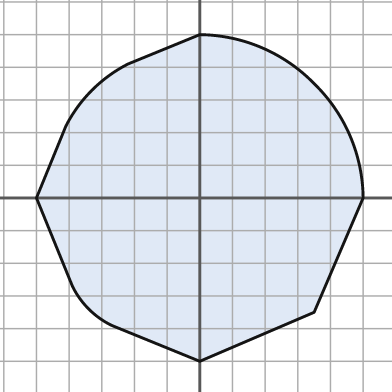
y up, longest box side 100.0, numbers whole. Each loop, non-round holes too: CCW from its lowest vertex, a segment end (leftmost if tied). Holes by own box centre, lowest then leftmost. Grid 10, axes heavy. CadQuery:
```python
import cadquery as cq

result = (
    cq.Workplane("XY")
    .moveTo(0.0, -50.0)
    .lineTo(35.0, -35.0)
    .lineTo(50.0, 0.0)
    .threePointArc((46.0, 19.0), (35.0, 35.0))
    .threePointArc((19.0, 46.0), (0.0, 50.0))
    .lineTo(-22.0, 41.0)
    .threePointArc((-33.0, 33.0), (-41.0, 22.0))
    .lineTo(-50.0, 0.0)
    .lineTo(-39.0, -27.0)
    .threePointArc((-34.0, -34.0), (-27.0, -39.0))
    .close()
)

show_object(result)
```